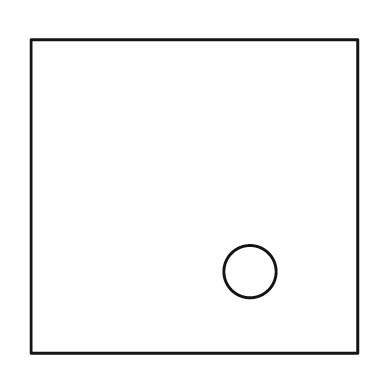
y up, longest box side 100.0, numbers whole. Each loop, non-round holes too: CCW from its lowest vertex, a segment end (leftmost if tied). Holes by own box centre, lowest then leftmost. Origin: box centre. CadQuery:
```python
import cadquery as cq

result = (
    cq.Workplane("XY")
    .moveTo(-50.0, -48.0)
    .lineTo(50.0, -48.0)
    .lineTo(50.0, 48.0)
    .lineTo(-50.0, 48.0)
    .close()
    .moveTo(17.0, -23.0)
    .circle(8.0)
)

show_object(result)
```